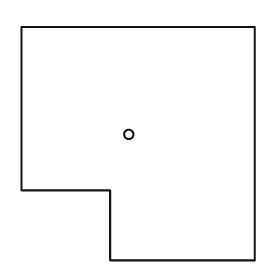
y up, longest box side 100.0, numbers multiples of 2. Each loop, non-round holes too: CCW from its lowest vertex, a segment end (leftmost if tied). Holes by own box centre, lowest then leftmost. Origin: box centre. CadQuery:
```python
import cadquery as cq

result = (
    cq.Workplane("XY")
    .moveTo(-12.0, -50.0)
    .lineTo(50.0, -50.0)
    .lineTo(50.0, 50.0)
    .lineTo(-50.0, 50.0)
    .lineTo(-50.0, -20.0)
    .lineTo(-12.0, -20.0)
    .close()
    .moveTo(-4.0, 4.0)
    .circle(2.0)
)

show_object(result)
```